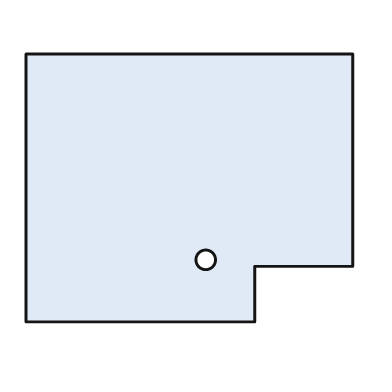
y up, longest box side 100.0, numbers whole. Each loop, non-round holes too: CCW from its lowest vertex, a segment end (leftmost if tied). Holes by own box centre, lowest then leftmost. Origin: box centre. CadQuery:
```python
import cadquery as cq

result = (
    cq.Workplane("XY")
    .moveTo(-50.0, -41.0)
    .lineTo(20.0, -41.0)
    .lineTo(20.0, -24.0)
    .lineTo(50.0, -24.0)
    .lineTo(50.0, 41.0)
    .lineTo(-50.0, 41.0)
    .close()
    .moveTo(5.0, -22.0)
    .circle(3.0)
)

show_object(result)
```